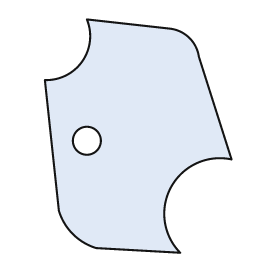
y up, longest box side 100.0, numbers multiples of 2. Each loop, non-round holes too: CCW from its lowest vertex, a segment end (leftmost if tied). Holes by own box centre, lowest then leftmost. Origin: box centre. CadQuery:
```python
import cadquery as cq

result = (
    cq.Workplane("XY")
    .moveTo(18.0, -50.0)
    .threePointArc((14.0, -22.0), (40.0, -10.0))
    .lineTo(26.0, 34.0)
    .threePointArc((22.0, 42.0), (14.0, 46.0))
    .lineTo(-22.0, 50.0)
    .threePointArc((-24.0, 32.0), (-40.0, 24.0))
    .lineTo(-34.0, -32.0)
    .threePointArc((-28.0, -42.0), (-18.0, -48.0))
    .close()
    .moveTo(-22.0, -2.0)
    .circle(6.0)
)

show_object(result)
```